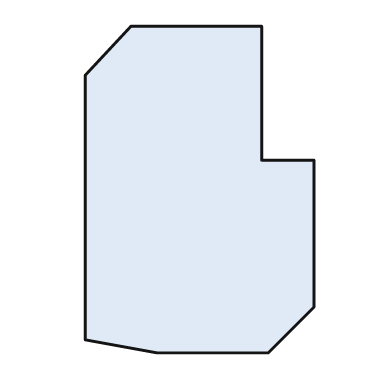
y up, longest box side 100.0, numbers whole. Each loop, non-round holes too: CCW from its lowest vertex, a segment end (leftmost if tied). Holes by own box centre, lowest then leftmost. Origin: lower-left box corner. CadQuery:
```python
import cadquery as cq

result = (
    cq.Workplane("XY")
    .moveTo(22.0, 0.0)
    .lineTo(56.0, 0.0)
    .lineTo(70.0, 14.0)
    .lineTo(70.0, 59.0)
    .lineTo(54.0, 59.0)
    .lineTo(54.0, 100.0)
    .lineTo(14.0, 100.0)
    .lineTo(0.0, 85.0)
    .lineTo(0.0, 4.0)
    .close()
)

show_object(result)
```